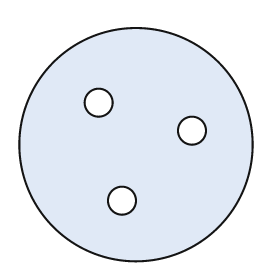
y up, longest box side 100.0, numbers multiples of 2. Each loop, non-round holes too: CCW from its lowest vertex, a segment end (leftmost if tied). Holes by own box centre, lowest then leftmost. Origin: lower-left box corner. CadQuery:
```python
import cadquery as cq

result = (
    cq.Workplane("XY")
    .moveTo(50.0, 50.0)
    .circle(50.0)
    .moveTo(44.0, 26.0)
    .circle(6.0)
    .moveTo(74.0, 56.0)
    .circle(6.0)
    .moveTo(34.0, 68.0)
    .circle(6.0)
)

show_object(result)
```